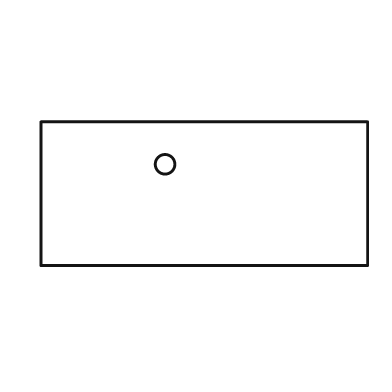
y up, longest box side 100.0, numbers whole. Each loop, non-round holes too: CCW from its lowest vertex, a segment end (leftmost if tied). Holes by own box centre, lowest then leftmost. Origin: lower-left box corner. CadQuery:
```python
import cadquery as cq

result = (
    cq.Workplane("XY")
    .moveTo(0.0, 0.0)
    .lineTo(100.0, 0.0)
    .lineTo(100.0, 44.0)
    .lineTo(0.0, 44.0)
    .close()
    .moveTo(38.0, 31.0)
    .circle(3.0)
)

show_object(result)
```